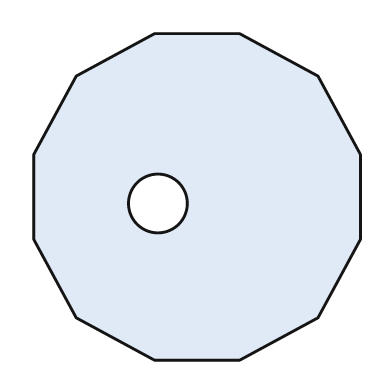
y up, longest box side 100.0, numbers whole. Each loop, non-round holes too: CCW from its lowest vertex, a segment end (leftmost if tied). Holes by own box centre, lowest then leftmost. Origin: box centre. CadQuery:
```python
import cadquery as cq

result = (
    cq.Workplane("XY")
    .moveTo(-13.0, -50.0)
    .lineTo(13.0, -50.0)
    .lineTo(37.0, -37.0)
    .lineTo(50.0, -13.0)
    .lineTo(50.0, 13.0)
    .lineTo(37.0, 37.0)
    .lineTo(13.0, 50.0)
    .lineTo(-13.0, 50.0)
    .lineTo(-37.0, 37.0)
    .lineTo(-50.0, 13.0)
    .lineTo(-50.0, -13.0)
    .lineTo(-37.0, -37.0)
    .close()
    .moveTo(-12.0, -2.0)
    .circle(9.0)
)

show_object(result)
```